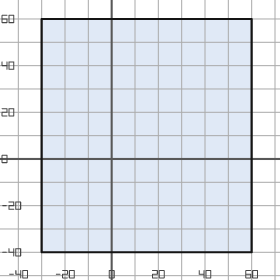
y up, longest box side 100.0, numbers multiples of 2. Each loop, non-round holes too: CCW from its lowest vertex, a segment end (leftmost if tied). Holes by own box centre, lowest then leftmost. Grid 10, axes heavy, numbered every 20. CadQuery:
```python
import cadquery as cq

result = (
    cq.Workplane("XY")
    .moveTo(-30.0, -40.0)
    .lineTo(60.0, -40.0)
    .lineTo(60.0, 60.0)
    .lineTo(-30.0, 60.0)
    .close()
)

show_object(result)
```